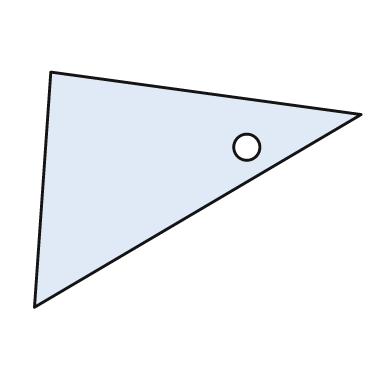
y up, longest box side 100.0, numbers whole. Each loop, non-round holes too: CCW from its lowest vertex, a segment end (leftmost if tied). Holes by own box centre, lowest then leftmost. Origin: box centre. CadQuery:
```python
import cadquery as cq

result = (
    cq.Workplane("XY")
    .moveTo(-50.0, -36.0)
    .lineTo(50.0, 23.0)
    .lineTo(-45.0, 36.0)
    .close()
    .moveTo(15.0, 13.0)
    .circle(4.0)
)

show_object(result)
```